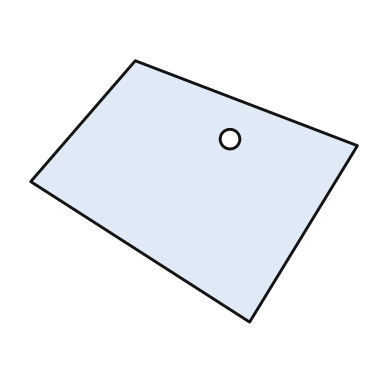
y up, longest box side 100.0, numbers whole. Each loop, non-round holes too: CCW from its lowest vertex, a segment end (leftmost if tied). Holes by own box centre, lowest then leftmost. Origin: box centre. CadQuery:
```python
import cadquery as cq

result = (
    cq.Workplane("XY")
    .moveTo(17.0, -40.0)
    .lineTo(50.0, 14.0)
    .lineTo(-18.0, 40.0)
    .lineTo(-50.0, 3.0)
    .close()
    .moveTo(11.0, 16.0)
    .circle(3.0)
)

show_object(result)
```